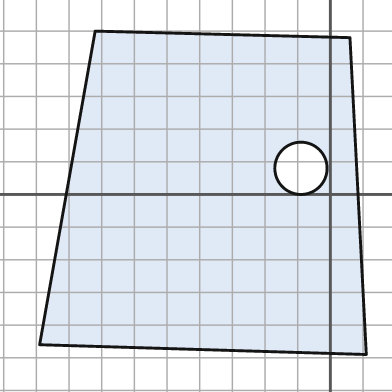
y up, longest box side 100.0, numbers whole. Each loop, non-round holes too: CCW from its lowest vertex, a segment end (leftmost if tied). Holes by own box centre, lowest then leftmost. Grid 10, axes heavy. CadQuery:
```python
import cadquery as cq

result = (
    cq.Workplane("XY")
    .moveTo(11.0, -49.0)
    .lineTo(6.0, 48.0)
    .lineTo(-72.0, 50.0)
    .lineTo(-89.0, -46.0)
    .close()
    .moveTo(-9.0, 8.0)
    .circle(8.0)
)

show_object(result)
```